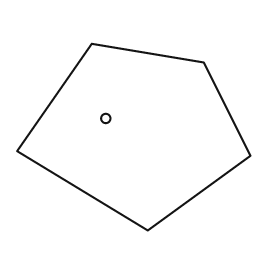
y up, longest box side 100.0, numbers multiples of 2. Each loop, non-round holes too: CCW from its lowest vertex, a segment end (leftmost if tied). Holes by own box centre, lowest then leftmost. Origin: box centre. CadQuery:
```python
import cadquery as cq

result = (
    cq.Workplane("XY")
    .moveTo(6.0, -40.0)
    .lineTo(50.0, -8.0)
    .lineTo(30.0, 32.0)
    .lineTo(-18.0, 40.0)
    .lineTo(-50.0, -6.0)
    .close()
    .moveTo(-12.0, 8.0)
    .circle(2.0)
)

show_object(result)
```